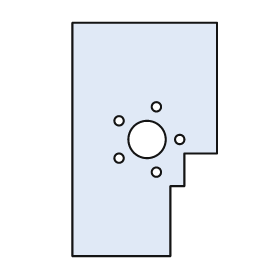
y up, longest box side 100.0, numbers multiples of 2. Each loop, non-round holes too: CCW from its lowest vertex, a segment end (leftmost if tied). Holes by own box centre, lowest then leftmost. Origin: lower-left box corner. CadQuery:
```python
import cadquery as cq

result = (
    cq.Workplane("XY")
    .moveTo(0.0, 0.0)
    .lineTo(42.0, 0.0)
    .lineTo(42.0, 30.0)
    .lineTo(48.0, 30.0)
    .lineTo(48.0, 44.0)
    .lineTo(62.0, 44.0)
    .lineTo(62.0, 100.0)
    .lineTo(0.0, 100.0)
    .close()
    .moveTo(36.0, 36.0)
    .circle(2.0)
    .moveTo(20.0, 42.0)
    .circle(2.0)
    .moveTo(32.0, 50.0)
    .circle(8.0)
    .moveTo(46.0, 50.0)
    .circle(2.0)
    .moveTo(20.0, 58.0)
    .circle(2.0)
    .moveTo(36.0, 64.0)
    .circle(2.0)
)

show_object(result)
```